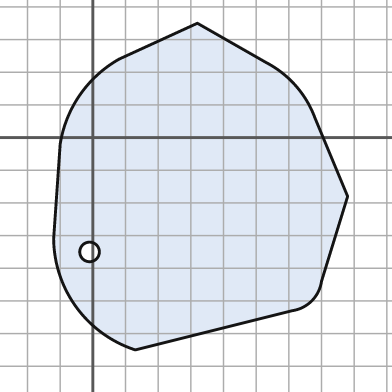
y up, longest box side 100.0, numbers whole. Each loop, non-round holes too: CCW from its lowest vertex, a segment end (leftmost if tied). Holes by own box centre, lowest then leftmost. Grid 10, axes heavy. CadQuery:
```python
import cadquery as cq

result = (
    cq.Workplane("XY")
    .moveTo(13.0, -65.0)
    .lineTo(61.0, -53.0)
    .threePointArc((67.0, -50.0), (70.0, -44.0))
    .lineTo(78.0, -18.0)
    .lineTo(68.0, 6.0)
    .threePointArc((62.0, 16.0), (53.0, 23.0))
    .lineTo(32.0, 35.0)
    .lineTo(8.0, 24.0)
    .threePointArc((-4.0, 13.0), (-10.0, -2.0))
    .lineTo(-12.0, -31.0)
    .threePointArc((-5.0, -52.0), (13.0, -65.0))
    .close()
    .moveTo(-1.0, -35.0)
    .circle(3.0)
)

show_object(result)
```